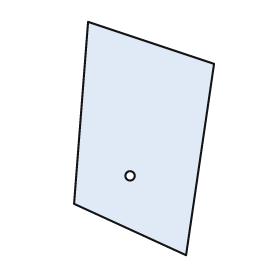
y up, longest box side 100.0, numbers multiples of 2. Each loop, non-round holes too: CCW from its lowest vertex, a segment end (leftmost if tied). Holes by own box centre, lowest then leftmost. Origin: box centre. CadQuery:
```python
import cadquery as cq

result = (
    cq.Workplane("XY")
    .moveTo(18.0, -50.0)
    .lineTo(30.0, 32.0)
    .lineTo(-24.0, 50.0)
    .lineTo(-30.0, -28.0)
    .close()
    .moveTo(-6.0, -16.0)
    .circle(2.0)
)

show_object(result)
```